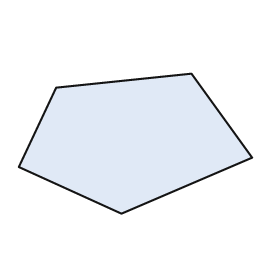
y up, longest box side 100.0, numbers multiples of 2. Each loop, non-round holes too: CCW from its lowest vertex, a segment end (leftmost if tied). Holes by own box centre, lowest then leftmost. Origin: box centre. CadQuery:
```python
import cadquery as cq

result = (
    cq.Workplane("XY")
    .moveTo(-6.0, -30.0)
    .lineTo(50.0, -6.0)
    .lineTo(24.0, 30.0)
    .lineTo(-34.0, 24.0)
    .lineTo(-50.0, -10.0)
    .close()
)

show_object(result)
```